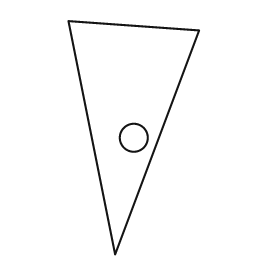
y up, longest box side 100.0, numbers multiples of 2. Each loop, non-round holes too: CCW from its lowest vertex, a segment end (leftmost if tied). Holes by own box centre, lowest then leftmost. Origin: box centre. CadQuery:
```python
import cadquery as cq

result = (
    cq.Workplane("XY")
    .moveTo(-8.0, -50.0)
    .lineTo(28.0, 46.0)
    .lineTo(-28.0, 50.0)
    .close()
    .moveTo(0.0, 0.0)
    .circle(6.0)
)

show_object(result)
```